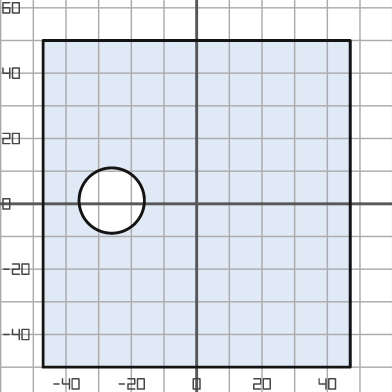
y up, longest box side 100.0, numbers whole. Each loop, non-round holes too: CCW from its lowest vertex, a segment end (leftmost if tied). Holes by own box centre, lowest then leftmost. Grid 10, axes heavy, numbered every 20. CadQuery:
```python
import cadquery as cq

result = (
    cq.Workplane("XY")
    .moveTo(-47.0, -50.0)
    .lineTo(47.0, -50.0)
    .lineTo(47.0, 50.0)
    .lineTo(-47.0, 50.0)
    .close()
    .moveTo(-26.0, 1.0)
    .circle(10.0)
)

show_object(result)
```